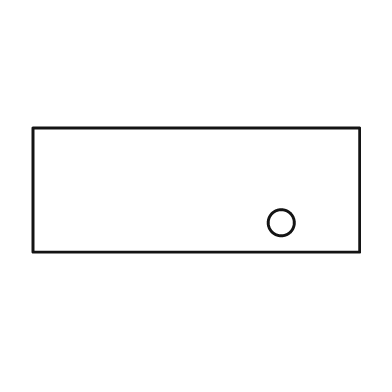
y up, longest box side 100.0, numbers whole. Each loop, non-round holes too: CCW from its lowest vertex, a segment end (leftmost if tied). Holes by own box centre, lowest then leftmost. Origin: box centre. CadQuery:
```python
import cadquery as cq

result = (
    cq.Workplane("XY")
    .moveTo(-50.0, -19.0)
    .lineTo(50.0, -19.0)
    .lineTo(50.0, 19.0)
    .lineTo(-50.0, 19.0)
    .close()
    .moveTo(26.0, -10.0)
    .circle(4.0)
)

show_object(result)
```